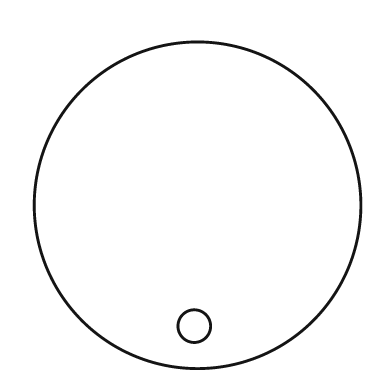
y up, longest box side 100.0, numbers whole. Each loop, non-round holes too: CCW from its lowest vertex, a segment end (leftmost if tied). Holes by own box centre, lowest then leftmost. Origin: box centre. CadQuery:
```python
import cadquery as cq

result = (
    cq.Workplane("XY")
    .moveTo(0.0, 0.0)
    .circle(50.0)
    .moveTo(-1.0, -37.0)
    .circle(5.0)
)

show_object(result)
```